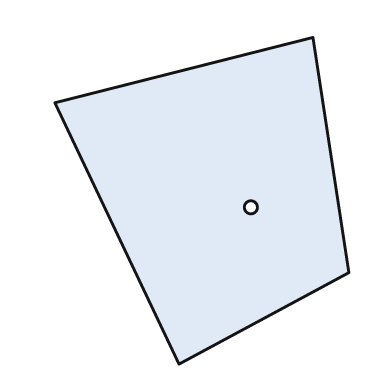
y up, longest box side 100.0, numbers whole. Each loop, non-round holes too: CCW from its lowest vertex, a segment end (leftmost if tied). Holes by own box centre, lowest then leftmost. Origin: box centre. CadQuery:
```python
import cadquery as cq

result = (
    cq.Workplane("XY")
    .moveTo(-7.0, -50.0)
    .lineTo(45.0, -22.0)
    .lineTo(34.0, 50.0)
    .lineTo(-45.0, 30.0)
    .close()
    .moveTo(15.0, -2.0)
    .circle(2.0)
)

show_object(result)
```